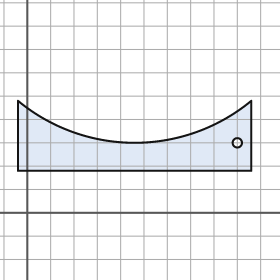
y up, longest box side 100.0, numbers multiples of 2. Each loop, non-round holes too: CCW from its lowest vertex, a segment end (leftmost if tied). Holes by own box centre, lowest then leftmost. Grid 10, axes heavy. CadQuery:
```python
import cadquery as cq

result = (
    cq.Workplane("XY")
    .moveTo(-4.0, 18.0)
    .lineTo(96.0, 18.0)
    .lineTo(96.0, 48.0)
    .threePointArc((46.0, 30.0), (-4.0, 48.0))
    .close()
    .moveTo(90.0, 30.0)
    .circle(2.0)
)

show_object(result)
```